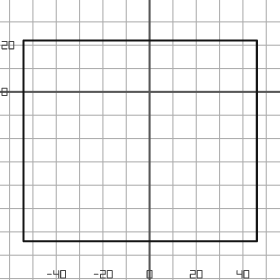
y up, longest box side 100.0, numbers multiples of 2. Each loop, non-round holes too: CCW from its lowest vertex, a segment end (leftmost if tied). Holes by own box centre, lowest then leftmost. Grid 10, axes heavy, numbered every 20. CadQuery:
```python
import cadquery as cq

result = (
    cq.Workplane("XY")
    .moveTo(-54.0, -64.0)
    .lineTo(46.0, -64.0)
    .lineTo(46.0, 22.0)
    .lineTo(-54.0, 22.0)
    .close()
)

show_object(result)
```